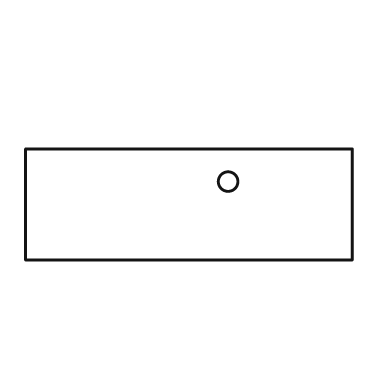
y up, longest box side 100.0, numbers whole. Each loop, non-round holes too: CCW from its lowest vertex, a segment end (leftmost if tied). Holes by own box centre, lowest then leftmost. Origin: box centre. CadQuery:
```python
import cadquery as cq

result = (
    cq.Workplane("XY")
    .moveTo(-50.0, -17.0)
    .lineTo(50.0, -17.0)
    .lineTo(50.0, 17.0)
    .lineTo(-50.0, 17.0)
    .close()
    .moveTo(12.0, 7.0)
    .circle(3.0)
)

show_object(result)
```